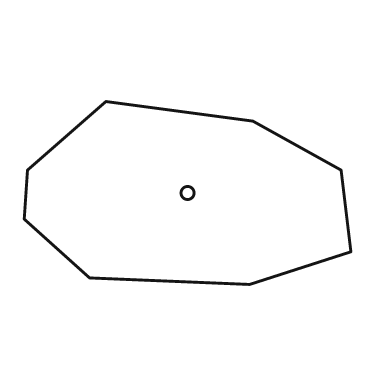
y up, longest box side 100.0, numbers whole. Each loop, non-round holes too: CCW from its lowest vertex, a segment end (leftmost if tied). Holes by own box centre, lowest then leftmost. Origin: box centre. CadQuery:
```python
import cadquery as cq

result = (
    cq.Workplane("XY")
    .moveTo(19.0, -28.0)
    .lineTo(50.0, -18.0)
    .lineTo(47.0, 7.0)
    .lineTo(20.0, 22.0)
    .lineTo(-25.0, 28.0)
    .lineTo(-49.0, 7.0)
    .lineTo(-50.0, -8.0)
    .lineTo(-30.0, -26.0)
    .close()
    .moveTo(0.0, 0.0)
    .circle(2.0)
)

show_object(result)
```